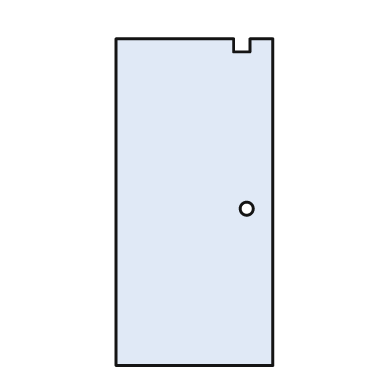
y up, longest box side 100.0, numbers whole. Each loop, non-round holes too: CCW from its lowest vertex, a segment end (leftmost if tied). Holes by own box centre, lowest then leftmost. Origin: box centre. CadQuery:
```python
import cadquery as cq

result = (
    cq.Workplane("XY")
    .moveTo(-24.0, -50.0)
    .lineTo(24.0, -50.0)
    .lineTo(24.0, 50.0)
    .lineTo(17.0, 50.0)
    .lineTo(17.0, 46.0)
    .lineTo(12.0, 46.0)
    .lineTo(12.0, 50.0)
    .lineTo(-24.0, 50.0)
    .close()
    .moveTo(16.0, -2.0)
    .circle(2.0)
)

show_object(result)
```